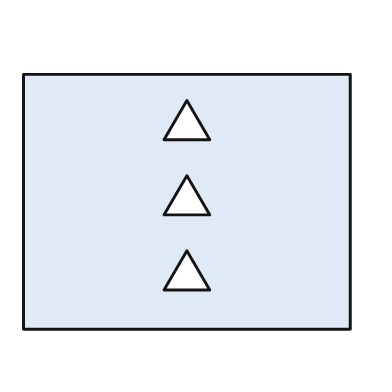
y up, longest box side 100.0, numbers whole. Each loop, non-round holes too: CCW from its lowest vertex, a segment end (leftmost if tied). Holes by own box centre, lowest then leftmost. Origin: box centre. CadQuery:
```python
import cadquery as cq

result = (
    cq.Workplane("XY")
    .moveTo(-50.0, -39.0)
    .lineTo(50.0, -39.0)
    .lineTo(50.0, 39.0)
    .lineTo(-50.0, 39.0)
    .close()
    .moveTo(-7.0, -27.0)
    .lineTo(7.0, -27.0)
    .lineTo(0.0, -15.0)
    .close()
    .moveTo(-7.0, -4.0)
    .lineTo(7.0, -4.0)
    .lineTo(0.0, 8.0)
    .close()
    .moveTo(-7.0, 19.0)
    .lineTo(7.0, 19.0)
    .lineTo(0.0, 31.0)
    .close()
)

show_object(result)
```